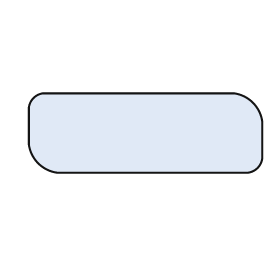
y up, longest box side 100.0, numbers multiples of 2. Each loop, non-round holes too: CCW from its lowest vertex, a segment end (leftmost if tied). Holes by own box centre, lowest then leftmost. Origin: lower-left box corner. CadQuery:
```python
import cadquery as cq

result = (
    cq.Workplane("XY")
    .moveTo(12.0, 0.0)
    .lineTo(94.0, 0.0)
    .threePointArc((98.0, 2.0), (100.0, 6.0))
    .lineTo(100.0, 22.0)
    .threePointArc((96.0, 30.0), (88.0, 34.0))
    .lineTo(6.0, 34.0)
    .threePointArc((2.0, 32.0), (0.0, 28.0))
    .lineTo(0.0, 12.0)
    .threePointArc((4.0, 4.0), (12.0, 0.0))
    .close()
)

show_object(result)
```